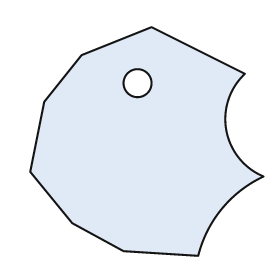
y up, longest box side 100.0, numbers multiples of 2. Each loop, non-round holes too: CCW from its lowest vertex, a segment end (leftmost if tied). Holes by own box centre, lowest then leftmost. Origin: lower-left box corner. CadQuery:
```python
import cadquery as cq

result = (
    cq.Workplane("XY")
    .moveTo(72.0, 0.0)
    .threePointArc((82.0, 20.0), (100.0, 34.0))
    .threePointArc((84.0, 54.0), (92.0, 78.0))
    .lineTo(52.0, 98.0)
    .lineTo(22.0, 86.0)
    .lineTo(6.0, 66.0)
    .lineTo(0.0, 36.0)
    .lineTo(18.0, 14.0)
    .lineTo(40.0, 2.0)
    .close()
    .moveTo(46.0, 74.0)
    .circle(6.0)
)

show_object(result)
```